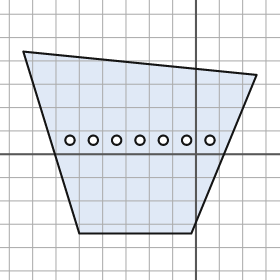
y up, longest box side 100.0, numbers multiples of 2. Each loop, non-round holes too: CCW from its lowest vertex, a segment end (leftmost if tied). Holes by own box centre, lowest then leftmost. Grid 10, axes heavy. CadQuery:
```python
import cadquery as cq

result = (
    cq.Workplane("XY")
    .moveTo(-50.0, -34.0)
    .lineTo(-2.0, -34.0)
    .lineTo(26.0, 34.0)
    .lineTo(-74.0, 44.0)
    .close()
    .moveTo(-54.0, 6.0)
    .circle(2.0)
    .moveTo(-44.0, 6.0)
    .circle(2.0)
    .moveTo(-34.0, 6.0)
    .circle(2.0)
    .moveTo(-24.0, 6.0)
    .circle(2.0)
    .moveTo(-14.0, 6.0)
    .circle(2.0)
    .moveTo(-4.0, 6.0)
    .circle(2.0)
    .moveTo(6.0, 6.0)
    .circle(2.0)
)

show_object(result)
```